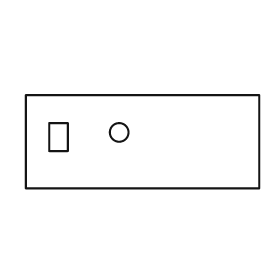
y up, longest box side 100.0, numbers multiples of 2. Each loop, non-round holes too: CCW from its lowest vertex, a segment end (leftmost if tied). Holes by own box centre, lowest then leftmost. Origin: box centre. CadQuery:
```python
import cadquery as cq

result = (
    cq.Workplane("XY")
    .moveTo(-50.0, -20.0)
    .lineTo(50.0, -20.0)
    .lineTo(50.0, 20.0)
    .lineTo(-50.0, 20.0)
    .close()
    .moveTo(-40.0, -4.0)
    .lineTo(-32.0, -4.0)
    .lineTo(-32.0, 8.0)
    .lineTo(-40.0, 8.0)
    .close()
    .moveTo(-10.0, 4.0)
    .circle(4.0)
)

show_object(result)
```